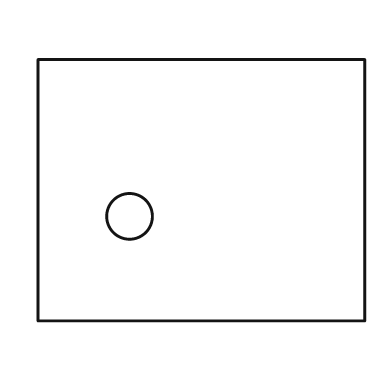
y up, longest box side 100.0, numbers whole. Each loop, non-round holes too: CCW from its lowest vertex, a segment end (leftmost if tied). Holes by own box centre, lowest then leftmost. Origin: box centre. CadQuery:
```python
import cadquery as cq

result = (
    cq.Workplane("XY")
    .moveTo(-50.0, -40.0)
    .lineTo(50.0, -40.0)
    .lineTo(50.0, 40.0)
    .lineTo(-50.0, 40.0)
    .close()
    .moveTo(-22.0, -8.0)
    .circle(7.0)
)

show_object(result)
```